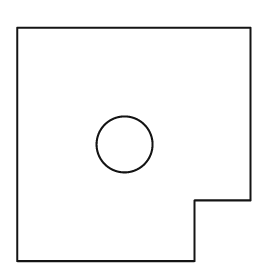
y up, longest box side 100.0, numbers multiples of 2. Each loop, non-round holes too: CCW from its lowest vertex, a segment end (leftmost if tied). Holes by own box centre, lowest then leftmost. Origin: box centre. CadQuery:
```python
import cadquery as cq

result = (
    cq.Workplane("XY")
    .moveTo(-50.0, -50.0)
    .lineTo(26.0, -50.0)
    .lineTo(26.0, -24.0)
    .lineTo(50.0, -24.0)
    .lineTo(50.0, 50.0)
    .lineTo(-50.0, 50.0)
    .close()
    .moveTo(-4.0, 0.0)
    .circle(12.0)
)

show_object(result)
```